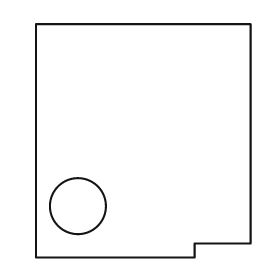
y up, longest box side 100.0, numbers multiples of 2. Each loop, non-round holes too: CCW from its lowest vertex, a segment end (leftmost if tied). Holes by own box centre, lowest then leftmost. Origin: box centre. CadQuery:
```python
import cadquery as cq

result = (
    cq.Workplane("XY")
    .moveTo(-46.0, -50.0)
    .lineTo(22.0, -50.0)
    .lineTo(22.0, -44.0)
    .lineTo(46.0, -44.0)
    .lineTo(46.0, 50.0)
    .lineTo(-46.0, 50.0)
    .close()
    .moveTo(-28.0, -28.0)
    .circle(12.0)
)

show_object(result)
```